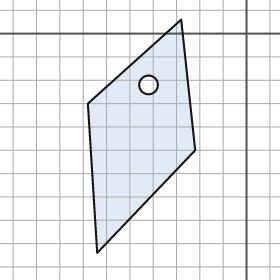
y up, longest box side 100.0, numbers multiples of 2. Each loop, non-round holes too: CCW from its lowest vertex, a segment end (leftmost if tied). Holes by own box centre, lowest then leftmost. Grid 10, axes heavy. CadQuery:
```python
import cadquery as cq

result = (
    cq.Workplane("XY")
    .moveTo(-64.0, -94.0)
    .lineTo(-22.0, -50.0)
    .lineTo(-28.0, 6.0)
    .lineTo(-68.0, -30.0)
    .close()
    .moveTo(-42.0, -22.0)
    .circle(4.0)
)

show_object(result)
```